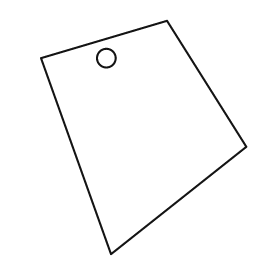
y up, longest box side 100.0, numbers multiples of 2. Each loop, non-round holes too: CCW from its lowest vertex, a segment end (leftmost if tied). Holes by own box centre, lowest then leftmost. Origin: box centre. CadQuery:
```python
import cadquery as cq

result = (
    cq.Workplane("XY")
    .moveTo(-14.0, -50.0)
    .lineTo(44.0, -4.0)
    .lineTo(10.0, 50.0)
    .lineTo(-44.0, 34.0)
    .close()
    .moveTo(-16.0, 34.0)
    .circle(4.0)
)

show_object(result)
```